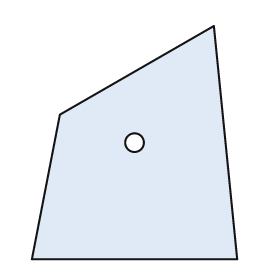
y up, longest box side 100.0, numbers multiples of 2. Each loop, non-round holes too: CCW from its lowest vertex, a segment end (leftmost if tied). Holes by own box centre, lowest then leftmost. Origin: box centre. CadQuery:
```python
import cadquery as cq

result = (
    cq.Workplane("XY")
    .moveTo(-44.0, -50.0)
    .lineTo(44.0, -50.0)
    .lineTo(34.0, 50.0)
    .lineTo(-32.0, 12.0)
    .close()
    .moveTo(0.0, 0.0)
    .circle(4.0)
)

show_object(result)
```